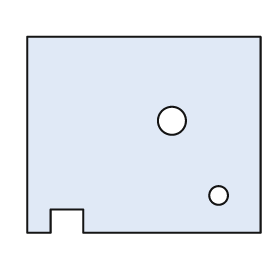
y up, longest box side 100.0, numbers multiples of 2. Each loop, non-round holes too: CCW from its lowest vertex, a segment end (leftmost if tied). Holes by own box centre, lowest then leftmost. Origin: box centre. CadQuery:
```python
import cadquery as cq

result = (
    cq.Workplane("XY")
    .moveTo(-50.0, -42.0)
    .lineTo(-40.0, -42.0)
    .lineTo(-40.0, -32.0)
    .lineTo(-26.0, -32.0)
    .lineTo(-26.0, -42.0)
    .lineTo(50.0, -42.0)
    .lineTo(50.0, 42.0)
    .lineTo(-50.0, 42.0)
    .close()
    .moveTo(32.0, -26.0)
    .circle(4.0)
    .moveTo(12.0, 6.0)
    .circle(6.0)
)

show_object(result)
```